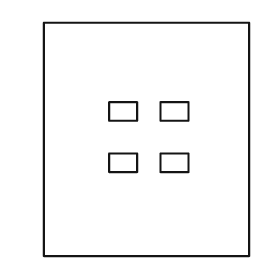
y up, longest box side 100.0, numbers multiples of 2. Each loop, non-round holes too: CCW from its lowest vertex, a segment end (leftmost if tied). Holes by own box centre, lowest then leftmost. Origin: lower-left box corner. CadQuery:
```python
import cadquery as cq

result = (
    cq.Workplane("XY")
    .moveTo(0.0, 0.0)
    .lineTo(88.0, 0.0)
    .lineTo(88.0, 100.0)
    .lineTo(0.0, 100.0)
    .close()
    .moveTo(28.0, 36.0)
    .lineTo(40.0, 36.0)
    .lineTo(40.0, 44.0)
    .lineTo(28.0, 44.0)
    .close()
    .moveTo(50.0, 36.0)
    .lineTo(62.0, 36.0)
    .lineTo(62.0, 44.0)
    .lineTo(50.0, 44.0)
    .close()
    .moveTo(28.0, 58.0)
    .lineTo(40.0, 58.0)
    .lineTo(40.0, 66.0)
    .lineTo(28.0, 66.0)
    .close()
    .moveTo(50.0, 58.0)
    .lineTo(62.0, 58.0)
    .lineTo(62.0, 66.0)
    .lineTo(50.0, 66.0)
    .close()
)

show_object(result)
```